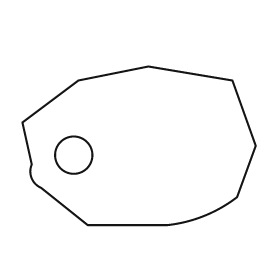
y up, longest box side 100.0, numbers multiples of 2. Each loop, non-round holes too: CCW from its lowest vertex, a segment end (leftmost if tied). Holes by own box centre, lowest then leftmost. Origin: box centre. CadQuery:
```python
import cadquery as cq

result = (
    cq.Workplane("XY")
    .moveTo(-22.0, -34.0)
    .lineTo(12.0, -34.0)
    .threePointArc((28.0, -30.0), (42.0, -22.0))
    .lineTo(50.0, 0.0)
    .lineTo(40.0, 28.0)
    .lineTo(4.0, 34.0)
    .lineTo(-26.0, 28.0)
    .lineTo(-50.0, 10.0)
    .lineTo(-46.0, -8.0)
    .threePointArc((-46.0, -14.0), (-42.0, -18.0))
    .close()
    .moveTo(-28.0, -4.0)
    .circle(8.0)
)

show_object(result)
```